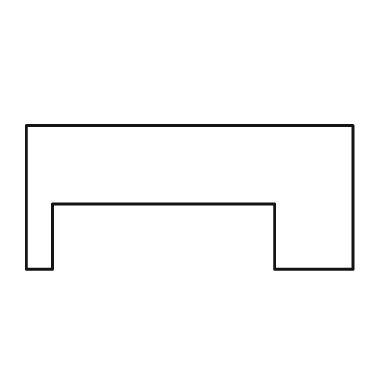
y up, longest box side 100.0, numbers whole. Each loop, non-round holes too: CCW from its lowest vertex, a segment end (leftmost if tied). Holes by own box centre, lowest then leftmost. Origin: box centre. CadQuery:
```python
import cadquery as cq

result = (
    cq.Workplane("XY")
    .moveTo(-50.0, -22.0)
    .lineTo(-42.0, -22.0)
    .lineTo(-42.0, -2.0)
    .lineTo(26.0, -2.0)
    .lineTo(26.0, -22.0)
    .lineTo(50.0, -22.0)
    .lineTo(50.0, 22.0)
    .lineTo(-50.0, 22.0)
    .close()
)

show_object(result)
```